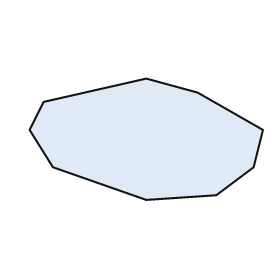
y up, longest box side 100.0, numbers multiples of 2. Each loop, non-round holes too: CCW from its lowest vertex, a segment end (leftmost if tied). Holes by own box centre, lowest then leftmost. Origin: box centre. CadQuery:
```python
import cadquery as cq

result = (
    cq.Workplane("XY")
    .moveTo(0.0, -26.0)
    .lineTo(30.0, -24.0)
    .lineTo(46.0, -12.0)
    .lineTo(50.0, 4.0)
    .lineTo(22.0, 20.0)
    .lineTo(0.0, 26.0)
    .lineTo(-44.0, 16.0)
    .lineTo(-50.0, 4.0)
    .lineTo(-40.0, -12.0)
    .close()
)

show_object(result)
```